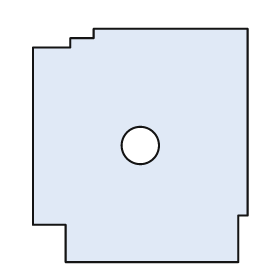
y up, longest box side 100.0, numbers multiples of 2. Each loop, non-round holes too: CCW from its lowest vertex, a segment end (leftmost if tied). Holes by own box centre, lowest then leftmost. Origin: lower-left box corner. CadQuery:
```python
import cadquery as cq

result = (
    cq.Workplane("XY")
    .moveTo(14.0, 0.0)
    .lineTo(88.0, 0.0)
    .lineTo(88.0, 20.0)
    .lineTo(92.0, 20.0)
    .lineTo(92.0, 100.0)
    .lineTo(26.0, 100.0)
    .lineTo(26.0, 96.0)
    .lineTo(16.0, 96.0)
    .lineTo(16.0, 92.0)
    .lineTo(0.0, 92.0)
    .lineTo(0.0, 16.0)
    .lineTo(14.0, 16.0)
    .close()
    .moveTo(46.0, 50.0)
    .circle(8.0)
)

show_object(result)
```